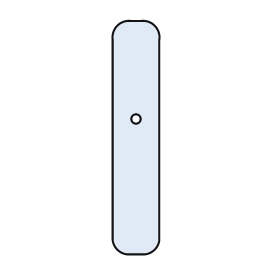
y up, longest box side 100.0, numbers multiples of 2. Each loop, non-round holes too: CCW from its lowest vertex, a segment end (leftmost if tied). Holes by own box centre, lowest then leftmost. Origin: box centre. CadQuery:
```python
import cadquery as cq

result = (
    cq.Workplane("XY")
    .moveTo(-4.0, -50.0)
    .lineTo(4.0, -50.0)
    .threePointArc((8.0, -48.0), (10.0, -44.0))
    .lineTo(10.0, 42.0)
    .threePointArc((8.0, 48.0), (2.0, 50.0))
    .lineTo(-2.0, 50.0)
    .threePointArc((-8.0, 48.0), (-10.0, 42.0))
    .lineTo(-10.0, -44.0)
    .threePointArc((-8.0, -48.0), (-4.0, -50.0))
    .close()
    .moveTo(0.0, 8.0)
    .circle(2.0)
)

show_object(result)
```